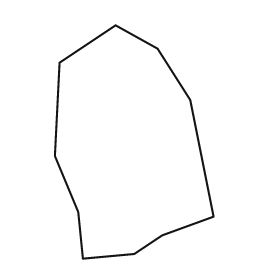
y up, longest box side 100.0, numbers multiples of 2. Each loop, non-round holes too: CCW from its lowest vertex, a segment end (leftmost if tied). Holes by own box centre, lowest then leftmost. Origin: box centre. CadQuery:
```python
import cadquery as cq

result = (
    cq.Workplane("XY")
    .moveTo(-22.0, -50.0)
    .lineTo(0.0, -48.0)
    .lineTo(12.0, -40.0)
    .lineTo(34.0, -32.0)
    .lineTo(24.0, 18.0)
    .lineTo(10.0, 40.0)
    .lineTo(-8.0, 50.0)
    .lineTo(-32.0, 34.0)
    .lineTo(-34.0, -6.0)
    .lineTo(-24.0, -30.0)
    .close()
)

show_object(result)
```